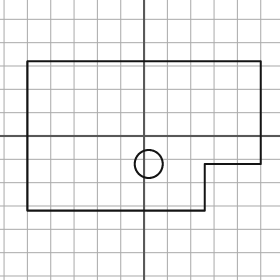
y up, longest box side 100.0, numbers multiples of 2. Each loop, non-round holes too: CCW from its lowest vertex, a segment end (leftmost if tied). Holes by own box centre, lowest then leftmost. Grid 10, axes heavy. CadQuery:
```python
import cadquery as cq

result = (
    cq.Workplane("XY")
    .moveTo(-50.0, -32.0)
    .lineTo(26.0, -32.0)
    .lineTo(26.0, -12.0)
    .lineTo(50.0, -12.0)
    .lineTo(50.0, 32.0)
    .lineTo(-50.0, 32.0)
    .close()
    .moveTo(2.0, -12.0)
    .circle(6.0)
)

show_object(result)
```